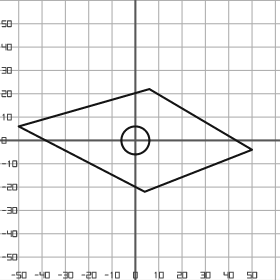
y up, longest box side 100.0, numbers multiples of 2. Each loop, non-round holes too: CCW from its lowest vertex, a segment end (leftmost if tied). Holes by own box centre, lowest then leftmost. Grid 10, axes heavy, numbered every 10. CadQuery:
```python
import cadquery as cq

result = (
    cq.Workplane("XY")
    .moveTo(4.0, -22.0)
    .lineTo(50.0, -4.0)
    .lineTo(6.0, 22.0)
    .lineTo(-50.0, 6.0)
    .close()
    .moveTo(0.0, 0.0)
    .circle(6.0)
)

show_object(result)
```